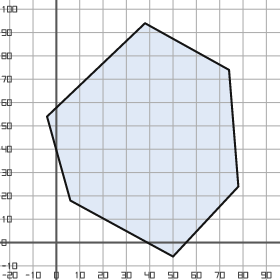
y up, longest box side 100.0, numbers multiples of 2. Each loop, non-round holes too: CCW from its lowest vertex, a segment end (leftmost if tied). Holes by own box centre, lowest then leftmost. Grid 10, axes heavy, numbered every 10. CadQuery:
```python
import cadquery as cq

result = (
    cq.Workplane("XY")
    .moveTo(50.0, -6.0)
    .lineTo(78.0, 24.0)
    .lineTo(74.0, 74.0)
    .lineTo(38.0, 94.0)
    .lineTo(-4.0, 54.0)
    .lineTo(6.0, 18.0)
    .close()
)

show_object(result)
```